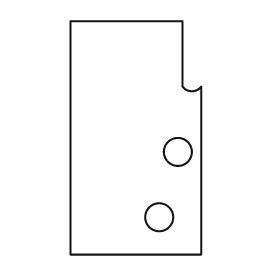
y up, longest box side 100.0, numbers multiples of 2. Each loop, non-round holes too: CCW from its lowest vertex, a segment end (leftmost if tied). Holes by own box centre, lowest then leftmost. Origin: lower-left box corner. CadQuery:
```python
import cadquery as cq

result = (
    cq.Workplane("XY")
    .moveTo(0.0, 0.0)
    .lineTo(56.0, 0.0)
    .lineTo(56.0, 72.0)
    .threePointArc((52.0, 70.0), (48.0, 72.0))
    .lineTo(48.0, 100.0)
    .lineTo(0.0, 100.0)
    .close()
    .moveTo(38.0, 16.0)
    .circle(6.0)
    .moveTo(46.0, 44.0)
    .circle(6.0)
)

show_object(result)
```